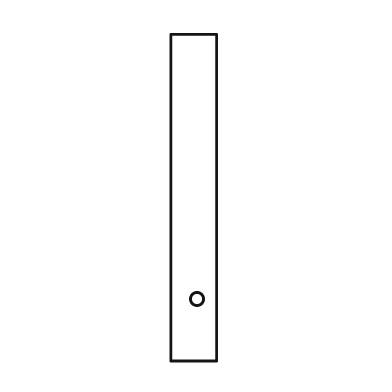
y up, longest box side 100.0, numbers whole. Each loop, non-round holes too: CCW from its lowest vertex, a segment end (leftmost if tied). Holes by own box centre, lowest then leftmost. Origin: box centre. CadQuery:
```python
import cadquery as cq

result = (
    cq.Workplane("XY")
    .moveTo(-7.0, -50.0)
    .lineTo(7.0, -50.0)
    .lineTo(7.0, 50.0)
    .lineTo(-7.0, 50.0)
    .close()
    .moveTo(1.0, -31.0)
    .circle(2.0)
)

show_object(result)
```